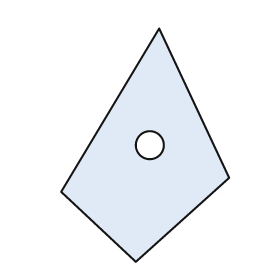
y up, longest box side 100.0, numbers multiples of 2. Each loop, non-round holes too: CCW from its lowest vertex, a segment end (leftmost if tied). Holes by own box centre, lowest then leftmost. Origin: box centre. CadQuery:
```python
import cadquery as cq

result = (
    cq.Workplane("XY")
    .moveTo(-4.0, -50.0)
    .lineTo(36.0, -14.0)
    .lineTo(6.0, 50.0)
    .lineTo(-36.0, -20.0)
    .close()
    .moveTo(2.0, 0.0)
    .circle(6.0)
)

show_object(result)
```